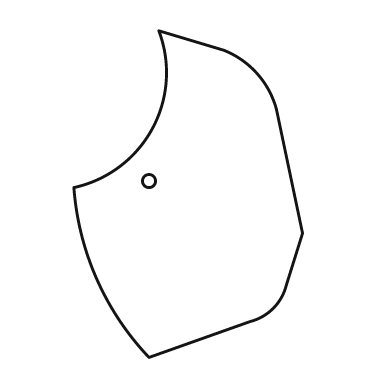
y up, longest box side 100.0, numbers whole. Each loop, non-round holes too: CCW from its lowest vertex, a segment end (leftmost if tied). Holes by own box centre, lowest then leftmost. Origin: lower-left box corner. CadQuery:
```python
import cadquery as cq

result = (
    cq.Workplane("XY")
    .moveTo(23.0, 0.0)
    .lineTo(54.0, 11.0)
    .threePointArc((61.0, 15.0), (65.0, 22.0))
    .lineTo(70.0, 38.0)
    .lineTo(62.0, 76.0)
    .threePointArc((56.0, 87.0), (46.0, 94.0))
    .lineTo(26.0, 100.0)
    .threePointArc((24.0, 70.0), (0.0, 52.0))
    .threePointArc((7.0, 24.0), (23.0, 0.0))
    .close()
    .moveTo(23.0, 54.0)
    .circle(2.0)
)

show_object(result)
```